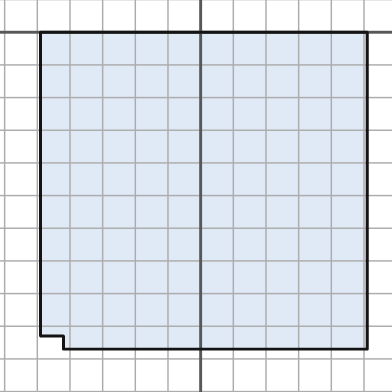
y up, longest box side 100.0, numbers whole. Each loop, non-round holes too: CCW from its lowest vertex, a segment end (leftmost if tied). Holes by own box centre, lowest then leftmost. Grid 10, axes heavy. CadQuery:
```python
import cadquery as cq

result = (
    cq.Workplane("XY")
    .moveTo(-42.0, -97.0)
    .lineTo(51.0, -97.0)
    .lineTo(51.0, 0.0)
    .lineTo(-49.0, 0.0)
    .lineTo(-49.0, -93.0)
    .lineTo(-42.0, -93.0)
    .close()
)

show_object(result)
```